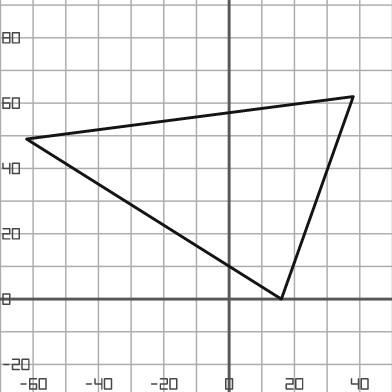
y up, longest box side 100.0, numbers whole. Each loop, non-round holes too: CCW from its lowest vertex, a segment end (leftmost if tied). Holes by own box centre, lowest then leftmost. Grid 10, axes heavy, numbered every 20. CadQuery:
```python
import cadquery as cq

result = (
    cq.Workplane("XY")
    .moveTo(16.0, 0.0)
    .lineTo(38.0, 62.0)
    .lineTo(-62.0, 49.0)
    .close()
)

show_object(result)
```